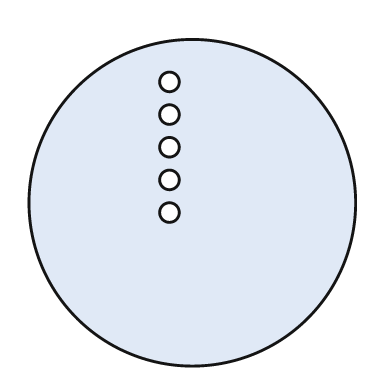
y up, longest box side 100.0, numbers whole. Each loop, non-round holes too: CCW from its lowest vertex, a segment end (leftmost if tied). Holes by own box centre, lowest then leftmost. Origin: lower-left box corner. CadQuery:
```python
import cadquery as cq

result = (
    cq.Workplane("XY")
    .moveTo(50.0, 50.0)
    .circle(50.0)
    .moveTo(43.0, 47.0)
    .circle(3.0)
    .moveTo(43.0, 57.0)
    .circle(3.0)
    .moveTo(43.0, 67.0)
    .circle(3.0)
    .moveTo(43.0, 77.0)
    .circle(3.0)
    .moveTo(43.0, 87.0)
    .circle(3.0)
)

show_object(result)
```